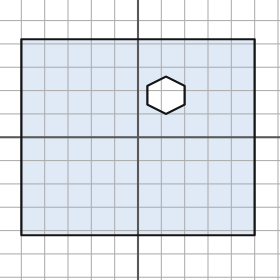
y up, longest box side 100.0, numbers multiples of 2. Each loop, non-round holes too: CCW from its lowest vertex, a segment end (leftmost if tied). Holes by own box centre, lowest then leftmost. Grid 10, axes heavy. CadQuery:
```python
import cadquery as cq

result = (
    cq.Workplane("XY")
    .moveTo(-50.0, -42.0)
    .lineTo(50.0, -42.0)
    .lineTo(50.0, 42.0)
    .lineTo(-50.0, 42.0)
    .close()
    .moveTo(12.0, 10.0)
    .lineTo(20.0, 14.0)
    .lineTo(20.0, 22.0)
    .lineTo(12.0, 26.0)
    .lineTo(4.0, 22.0)
    .lineTo(4.0, 14.0)
    .close()
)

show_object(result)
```